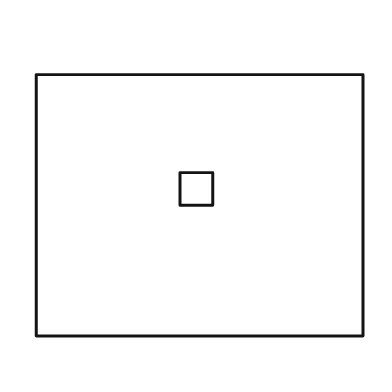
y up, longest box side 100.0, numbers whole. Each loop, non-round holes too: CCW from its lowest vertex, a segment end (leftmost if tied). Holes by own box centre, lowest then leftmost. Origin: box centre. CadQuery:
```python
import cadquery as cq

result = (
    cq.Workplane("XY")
    .moveTo(-50.0, -40.0)
    .lineTo(50.0, -40.0)
    .lineTo(50.0, 40.0)
    .lineTo(-50.0, 40.0)
    .close()
    .moveTo(-6.0, 0.0)
    .lineTo(4.0, 0.0)
    .lineTo(4.0, 10.0)
    .lineTo(-6.0, 10.0)
    .close()
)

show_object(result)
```